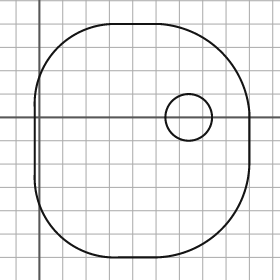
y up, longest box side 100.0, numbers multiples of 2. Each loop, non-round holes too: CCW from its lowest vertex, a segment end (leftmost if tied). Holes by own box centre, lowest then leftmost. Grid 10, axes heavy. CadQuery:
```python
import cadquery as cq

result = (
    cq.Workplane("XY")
    .moveTo(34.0, -60.0)
    .lineTo(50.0, -60.0)
    .threePointArc((78.0, -48.0), (90.0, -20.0))
    .lineTo(90.0, 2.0)
    .threePointArc((78.0, 28.0), (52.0, 40.0))
    .lineTo(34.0, 40.0)
    .threePointArc((8.0, 30.0), (-2.0, 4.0))
    .lineTo(-2.0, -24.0)
    .threePointArc((8.0, -50.0), (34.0, -60.0))
    .close()
    .moveTo(64.0, 0.0)
    .circle(10.0)
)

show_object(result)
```